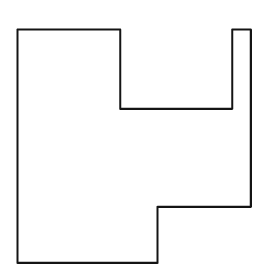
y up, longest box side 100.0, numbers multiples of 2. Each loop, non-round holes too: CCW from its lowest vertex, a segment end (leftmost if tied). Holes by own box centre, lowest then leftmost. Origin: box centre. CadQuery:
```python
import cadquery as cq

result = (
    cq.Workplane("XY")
    .moveTo(-50.0, -50.0)
    .lineTo(10.0, -50.0)
    .lineTo(10.0, -26.0)
    .lineTo(50.0, -26.0)
    .lineTo(50.0, 50.0)
    .lineTo(42.0, 50.0)
    .lineTo(42.0, 16.0)
    .lineTo(-6.0, 16.0)
    .lineTo(-6.0, 50.0)
    .lineTo(-50.0, 50.0)
    .close()
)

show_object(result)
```